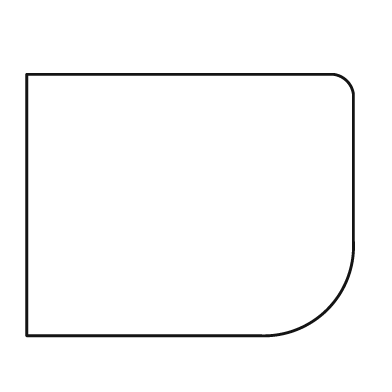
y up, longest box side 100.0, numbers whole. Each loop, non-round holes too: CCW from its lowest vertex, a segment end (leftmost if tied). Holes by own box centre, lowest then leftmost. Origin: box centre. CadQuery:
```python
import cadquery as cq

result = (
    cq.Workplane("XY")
    .moveTo(-50.0, -40.0)
    .lineTo(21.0, -40.0)
    .threePointArc((42.0, -32.0), (50.0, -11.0))
    .lineTo(50.0, 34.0)
    .threePointArc((48.0, 38.0), (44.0, 40.0))
    .lineTo(-50.0, 40.0)
    .close()
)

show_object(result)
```